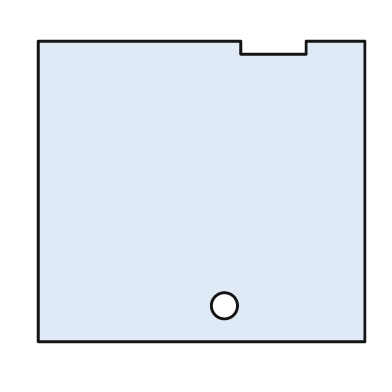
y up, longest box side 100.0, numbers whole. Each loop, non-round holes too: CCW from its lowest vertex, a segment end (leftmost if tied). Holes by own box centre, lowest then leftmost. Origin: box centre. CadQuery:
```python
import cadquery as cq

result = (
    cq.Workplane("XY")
    .moveTo(-50.0, -46.0)
    .lineTo(50.0, -46.0)
    .lineTo(50.0, 46.0)
    .lineTo(32.0, 46.0)
    .lineTo(32.0, 42.0)
    .lineTo(12.0, 42.0)
    .lineTo(12.0, 46.0)
    .lineTo(-50.0, 46.0)
    .close()
    .moveTo(7.0, -35.0)
    .circle(4.0)
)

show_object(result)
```